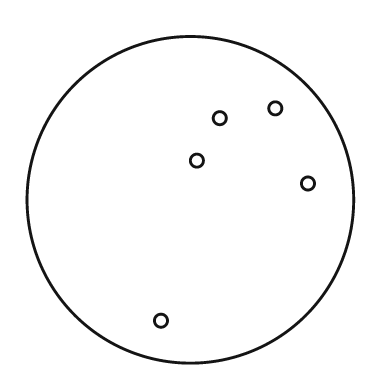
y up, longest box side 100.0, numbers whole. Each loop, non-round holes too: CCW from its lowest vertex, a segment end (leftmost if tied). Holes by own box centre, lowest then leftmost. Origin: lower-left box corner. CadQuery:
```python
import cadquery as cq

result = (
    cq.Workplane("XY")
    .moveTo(50.0, 50.0)
    .circle(50.0)
    .moveTo(41.0, 13.0)
    .circle(2.0)
    .moveTo(86.0, 55.0)
    .circle(2.0)
    .moveTo(52.0, 62.0)
    .circle(2.0)
    .moveTo(59.0, 75.0)
    .circle(2.0)
    .moveTo(76.0, 78.0)
    .circle(2.0)
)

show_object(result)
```